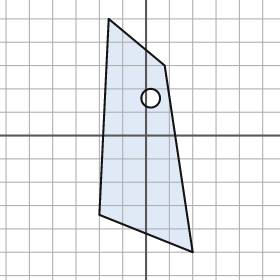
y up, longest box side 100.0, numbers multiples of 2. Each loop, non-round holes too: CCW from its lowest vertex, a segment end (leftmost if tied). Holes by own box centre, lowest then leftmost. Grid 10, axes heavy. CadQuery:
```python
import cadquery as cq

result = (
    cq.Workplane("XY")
    .moveTo(20.0, -50.0)
    .lineTo(8.0, 30.0)
    .lineTo(-16.0, 50.0)
    .lineTo(-20.0, -34.0)
    .close()
    .moveTo(2.0, 16.0)
    .circle(4.0)
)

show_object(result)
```